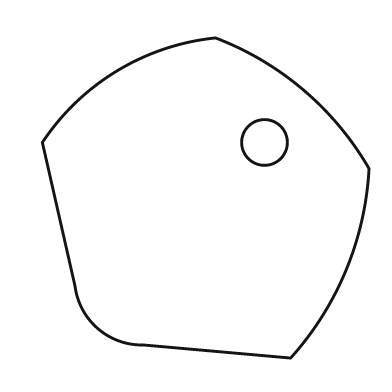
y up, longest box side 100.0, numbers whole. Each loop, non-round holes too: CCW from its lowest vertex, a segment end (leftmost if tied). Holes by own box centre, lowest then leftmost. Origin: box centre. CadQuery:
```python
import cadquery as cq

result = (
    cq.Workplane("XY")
    .moveTo(26.0, -49.0)
    .threePointArc((43.0, -22.0), (50.0, 9.0))
    .threePointArc((30.0, 33.0), (3.0, 49.0))
    .threePointArc((-27.0, 39.0), (-50.0, 17.0))
    .lineTo(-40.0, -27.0)
    .threePointArc((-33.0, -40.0), (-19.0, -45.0))
    .close()
    .moveTo(18.0, 17.0)
    .circle(7.0)
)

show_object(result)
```